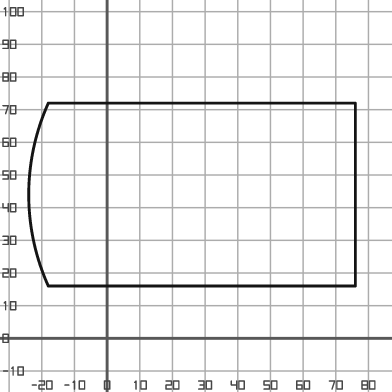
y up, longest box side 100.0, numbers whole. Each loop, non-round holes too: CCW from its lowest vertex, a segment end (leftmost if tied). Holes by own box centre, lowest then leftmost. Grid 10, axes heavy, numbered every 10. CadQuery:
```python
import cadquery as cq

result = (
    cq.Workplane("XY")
    .moveTo(-18.0, 16.0)
    .lineTo(76.0, 16.0)
    .lineTo(76.0, 72.0)
    .lineTo(-18.0, 72.0)
    .threePointArc((-24.0, 44.0), (-18.0, 16.0))
    .close()
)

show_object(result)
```